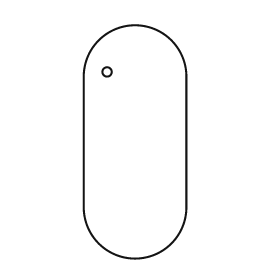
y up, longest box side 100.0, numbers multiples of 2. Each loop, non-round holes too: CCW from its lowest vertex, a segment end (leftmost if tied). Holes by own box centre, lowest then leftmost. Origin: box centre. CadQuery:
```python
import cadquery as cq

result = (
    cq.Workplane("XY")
    .moveTo(-22.0, -28.0)
    .threePointArc((0.0, -50.0), (22.0, -28.0))
    .lineTo(22.0, 28.0)
    .threePointArc((0.0, 50.0), (-22.0, 28.0))
    .close()
    .moveTo(-12.0, 30.0)
    .circle(2.0)
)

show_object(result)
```